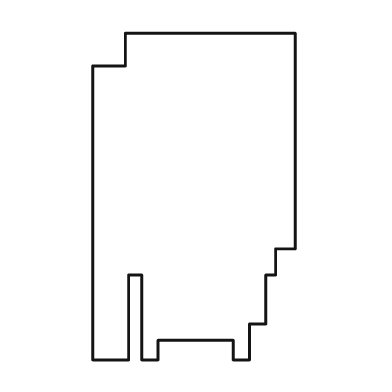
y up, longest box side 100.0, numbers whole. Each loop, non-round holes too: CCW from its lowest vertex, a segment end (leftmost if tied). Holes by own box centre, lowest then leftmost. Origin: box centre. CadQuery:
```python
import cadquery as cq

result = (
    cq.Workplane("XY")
    .moveTo(-31.0, -50.0)
    .lineTo(-20.0, -50.0)
    .lineTo(-20.0, -24.0)
    .lineTo(-16.0, -24.0)
    .lineTo(-16.0, -50.0)
    .lineTo(-11.0, -50.0)
    .lineTo(-11.0, -44.0)
    .lineTo(12.0, -44.0)
    .lineTo(12.0, -50.0)
    .lineTo(17.0, -50.0)
    .lineTo(17.0, -39.0)
    .lineTo(22.0, -39.0)
    .lineTo(22.0, -24.0)
    .lineTo(25.0, -24.0)
    .lineTo(25.0, -16.0)
    .lineTo(31.0, -16.0)
    .lineTo(31.0, 50.0)
    .lineTo(-21.0, 50.0)
    .lineTo(-21.0, 40.0)
    .lineTo(-31.0, 40.0)
    .close()
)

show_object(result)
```